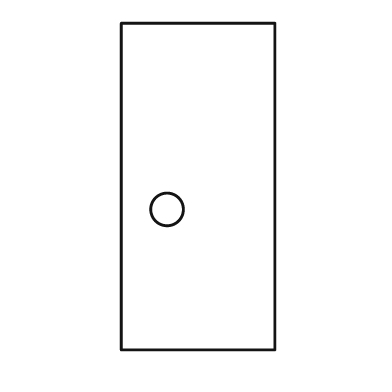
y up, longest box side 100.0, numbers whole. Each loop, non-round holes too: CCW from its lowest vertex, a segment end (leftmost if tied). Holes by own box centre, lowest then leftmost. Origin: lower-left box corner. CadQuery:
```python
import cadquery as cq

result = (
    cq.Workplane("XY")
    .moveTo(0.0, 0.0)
    .lineTo(47.0, 0.0)
    .lineTo(47.0, 100.0)
    .lineTo(0.0, 100.0)
    .close()
    .moveTo(14.0, 43.0)
    .circle(5.0)
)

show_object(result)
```